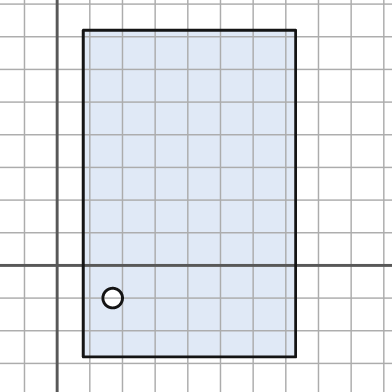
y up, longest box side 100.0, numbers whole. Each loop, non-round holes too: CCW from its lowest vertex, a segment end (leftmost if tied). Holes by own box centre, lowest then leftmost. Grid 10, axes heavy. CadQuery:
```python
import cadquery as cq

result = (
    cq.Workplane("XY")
    .moveTo(8.0, -28.0)
    .lineTo(73.0, -28.0)
    .lineTo(73.0, 72.0)
    .lineTo(8.0, 72.0)
    .close()
    .moveTo(17.0, -10.0)
    .circle(3.0)
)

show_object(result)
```